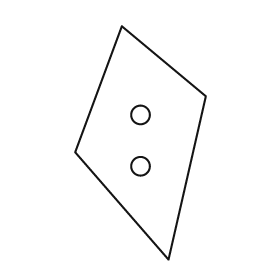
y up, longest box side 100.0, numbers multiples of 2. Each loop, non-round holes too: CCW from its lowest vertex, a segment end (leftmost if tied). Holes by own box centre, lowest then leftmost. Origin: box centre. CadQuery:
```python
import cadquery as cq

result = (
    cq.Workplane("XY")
    .moveTo(12.0, -50.0)
    .lineTo(28.0, 20.0)
    .lineTo(-8.0, 50.0)
    .lineTo(-28.0, -4.0)
    .close()
    .moveTo(0.0, -10.0)
    .circle(4.0)
    .moveTo(0.0, 12.0)
    .circle(4.0)
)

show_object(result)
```